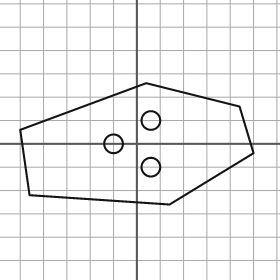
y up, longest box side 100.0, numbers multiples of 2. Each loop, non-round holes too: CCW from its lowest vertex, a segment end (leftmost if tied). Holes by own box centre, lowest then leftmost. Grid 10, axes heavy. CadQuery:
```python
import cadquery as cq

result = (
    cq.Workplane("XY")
    .moveTo(14.0, -26.0)
    .lineTo(50.0, -4.0)
    .lineTo(44.0, 16.0)
    .lineTo(4.0, 26.0)
    .lineTo(-50.0, 6.0)
    .lineTo(-46.0, -22.0)
    .close()
    .moveTo(6.0, -10.0)
    .circle(4.0)
    .moveTo(-10.0, 0.0)
    .circle(4.0)
    .moveTo(6.0, 10.0)
    .circle(4.0)
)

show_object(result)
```